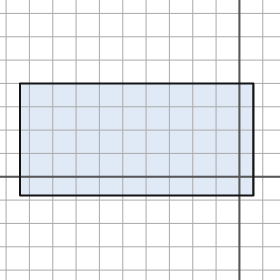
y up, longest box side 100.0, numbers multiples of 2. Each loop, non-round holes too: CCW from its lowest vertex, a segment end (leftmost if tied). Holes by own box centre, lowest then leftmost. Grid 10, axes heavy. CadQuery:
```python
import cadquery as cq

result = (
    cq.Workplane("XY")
    .moveTo(-94.0, -8.0)
    .lineTo(6.0, -8.0)
    .lineTo(6.0, 40.0)
    .lineTo(-94.0, 40.0)
    .close()
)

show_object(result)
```